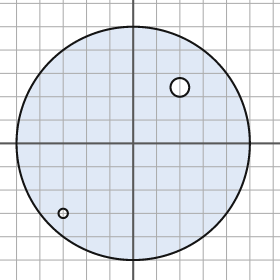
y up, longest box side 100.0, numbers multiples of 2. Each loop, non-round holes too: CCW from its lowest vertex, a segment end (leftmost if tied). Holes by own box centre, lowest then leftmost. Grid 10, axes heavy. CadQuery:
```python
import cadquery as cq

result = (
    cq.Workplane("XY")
    .moveTo(0.0, 0.0)
    .circle(50.0)
    .moveTo(-30.0, -30.0)
    .circle(2.0)
    .moveTo(20.0, 24.0)
    .circle(4.0)
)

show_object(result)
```